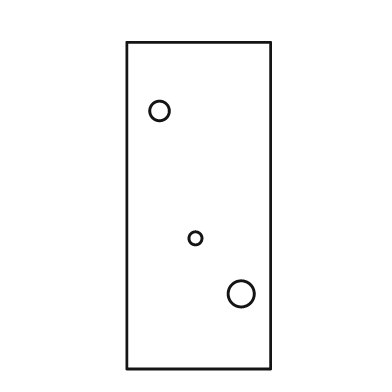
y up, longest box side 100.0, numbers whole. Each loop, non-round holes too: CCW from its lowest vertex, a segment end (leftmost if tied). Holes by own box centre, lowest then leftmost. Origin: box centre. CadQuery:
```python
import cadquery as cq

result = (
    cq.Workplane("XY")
    .moveTo(-22.0, -50.0)
    .lineTo(22.0, -50.0)
    .lineTo(22.0, 50.0)
    .lineTo(-22.0, 50.0)
    .close()
    .moveTo(13.0, -27.0)
    .circle(4.0)
    .moveTo(-1.0, -10.0)
    .circle(2.0)
    .moveTo(-12.0, 29.0)
    .circle(3.0)
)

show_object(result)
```